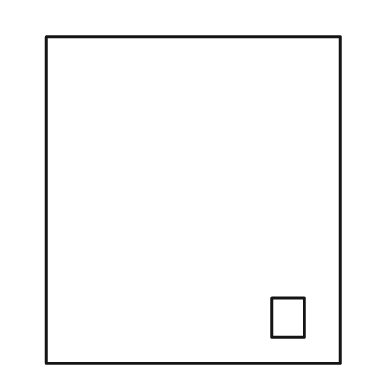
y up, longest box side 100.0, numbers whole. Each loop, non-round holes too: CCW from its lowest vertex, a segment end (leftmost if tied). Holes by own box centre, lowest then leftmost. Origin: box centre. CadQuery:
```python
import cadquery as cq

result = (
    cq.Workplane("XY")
    .moveTo(-45.0, -50.0)
    .lineTo(45.0, -50.0)
    .lineTo(45.0, 50.0)
    .lineTo(-45.0, 50.0)
    .close()
    .moveTo(24.0, -42.0)
    .lineTo(34.0, -42.0)
    .lineTo(34.0, -30.0)
    .lineTo(24.0, -30.0)
    .close()
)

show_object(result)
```